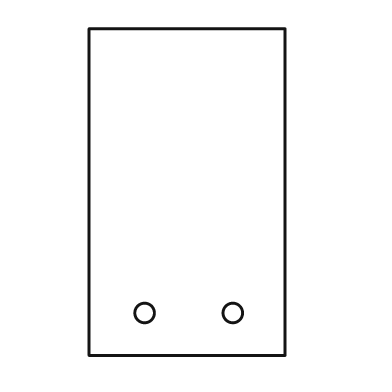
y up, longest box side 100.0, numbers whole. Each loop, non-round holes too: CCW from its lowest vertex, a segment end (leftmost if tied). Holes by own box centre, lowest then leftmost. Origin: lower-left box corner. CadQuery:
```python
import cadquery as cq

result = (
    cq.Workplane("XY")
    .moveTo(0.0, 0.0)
    .lineTo(60.0, 0.0)
    .lineTo(60.0, 100.0)
    .lineTo(0.0, 100.0)
    .close()
    .moveTo(17.0, 13.0)
    .circle(3.0)
    .moveTo(44.0, 13.0)
    .circle(3.0)
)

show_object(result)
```